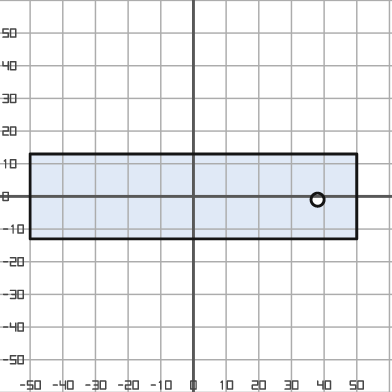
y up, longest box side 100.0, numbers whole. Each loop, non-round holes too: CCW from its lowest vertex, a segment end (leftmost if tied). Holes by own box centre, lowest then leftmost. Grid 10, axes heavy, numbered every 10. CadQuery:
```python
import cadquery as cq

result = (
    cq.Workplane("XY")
    .moveTo(-50.0, -13.0)
    .lineTo(50.0, -13.0)
    .lineTo(50.0, 13.0)
    .lineTo(-50.0, 13.0)
    .close()
    .moveTo(38.0, -1.0)
    .circle(2.0)
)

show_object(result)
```